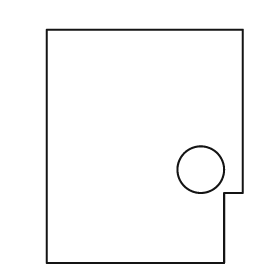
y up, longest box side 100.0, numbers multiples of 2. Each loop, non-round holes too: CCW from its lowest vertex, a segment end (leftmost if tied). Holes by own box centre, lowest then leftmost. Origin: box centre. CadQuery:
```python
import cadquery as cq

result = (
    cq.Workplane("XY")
    .moveTo(-42.0, -50.0)
    .lineTo(34.0, -50.0)
    .lineTo(34.0, -20.0)
    .lineTo(42.0, -20.0)
    .lineTo(42.0, 50.0)
    .lineTo(-42.0, 50.0)
    .close()
    .moveTo(24.0, -10.0)
    .circle(10.0)
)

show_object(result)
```